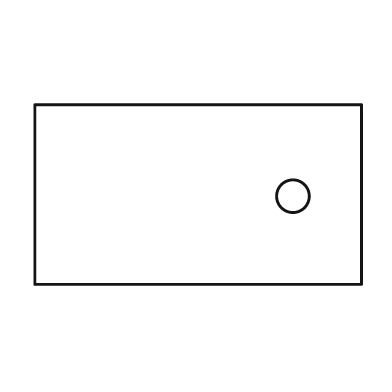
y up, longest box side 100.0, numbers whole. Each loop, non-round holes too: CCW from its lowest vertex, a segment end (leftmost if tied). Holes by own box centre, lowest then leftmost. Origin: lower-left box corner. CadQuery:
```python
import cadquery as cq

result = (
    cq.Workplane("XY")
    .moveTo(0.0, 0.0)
    .lineTo(100.0, 0.0)
    .lineTo(100.0, 55.0)
    .lineTo(0.0, 55.0)
    .close()
    .moveTo(79.0, 27.0)
    .circle(5.0)
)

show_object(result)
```